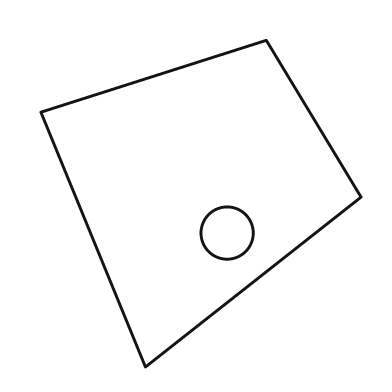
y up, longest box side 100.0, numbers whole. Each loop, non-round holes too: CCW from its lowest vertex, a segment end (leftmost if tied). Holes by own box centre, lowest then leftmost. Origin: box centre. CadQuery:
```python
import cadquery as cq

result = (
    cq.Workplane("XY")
    .moveTo(-17.0, -50.0)
    .lineTo(49.0, 2.0)
    .lineTo(20.0, 50.0)
    .lineTo(-49.0, 28.0)
    .close()
    .moveTo(8.0, -9.0)
    .circle(8.0)
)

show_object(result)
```